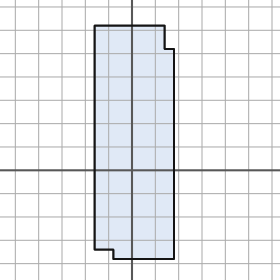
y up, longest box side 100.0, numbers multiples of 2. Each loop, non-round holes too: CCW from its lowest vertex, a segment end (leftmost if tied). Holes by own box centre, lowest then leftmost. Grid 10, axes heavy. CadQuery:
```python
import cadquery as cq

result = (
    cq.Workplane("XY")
    .moveTo(-8.0, -38.0)
    .lineTo(18.0, -38.0)
    .lineTo(18.0, 52.0)
    .lineTo(14.0, 52.0)
    .lineTo(14.0, 62.0)
    .lineTo(-16.0, 62.0)
    .lineTo(-16.0, -34.0)
    .lineTo(-8.0, -34.0)
    .close()
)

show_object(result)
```